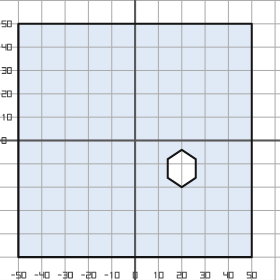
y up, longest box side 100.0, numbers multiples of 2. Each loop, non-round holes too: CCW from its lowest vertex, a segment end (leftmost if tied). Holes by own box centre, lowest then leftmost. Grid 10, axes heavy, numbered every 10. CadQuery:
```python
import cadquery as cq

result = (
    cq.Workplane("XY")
    .moveTo(-50.0, -50.0)
    .lineTo(50.0, -50.0)
    .lineTo(50.0, 50.0)
    .lineTo(-50.0, 50.0)
    .close()
    .moveTo(20.0, -20.0)
    .lineTo(26.0, -16.0)
    .lineTo(26.0, -8.0)
    .lineTo(20.0, -4.0)
    .lineTo(14.0, -8.0)
    .lineTo(14.0, -16.0)
    .close()
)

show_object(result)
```